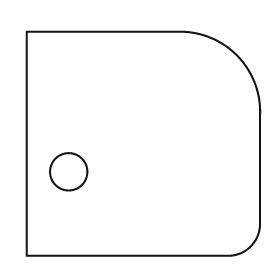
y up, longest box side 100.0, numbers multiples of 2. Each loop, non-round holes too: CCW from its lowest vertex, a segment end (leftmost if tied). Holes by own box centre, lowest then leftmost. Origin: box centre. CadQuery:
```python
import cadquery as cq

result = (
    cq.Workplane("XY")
    .moveTo(-50.0, -48.0)
    .lineTo(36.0, -48.0)
    .threePointArc((46.0, -44.0), (50.0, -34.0))
    .lineTo(50.0, 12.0)
    .threePointArc((40.0, 38.0), (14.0, 48.0))
    .lineTo(-50.0, 48.0)
    .close()
    .moveTo(-32.0, -12.0)
    .circle(8.0)
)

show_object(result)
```